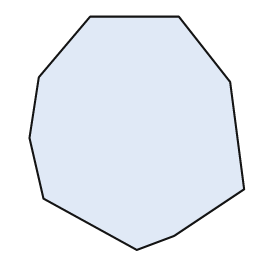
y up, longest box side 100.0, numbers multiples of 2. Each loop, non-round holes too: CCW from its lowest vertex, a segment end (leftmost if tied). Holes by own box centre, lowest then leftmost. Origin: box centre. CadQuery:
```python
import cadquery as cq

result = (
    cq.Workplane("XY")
    .moveTo(0.0, -50.0)
    .lineTo(16.0, -44.0)
    .lineTo(46.0, -24.0)
    .lineTo(40.0, 22.0)
    .lineTo(18.0, 50.0)
    .lineTo(-20.0, 50.0)
    .lineTo(-42.0, 24.0)
    .lineTo(-46.0, -2.0)
    .lineTo(-40.0, -28.0)
    .close()
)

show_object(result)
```